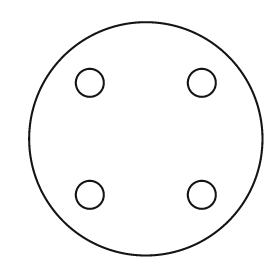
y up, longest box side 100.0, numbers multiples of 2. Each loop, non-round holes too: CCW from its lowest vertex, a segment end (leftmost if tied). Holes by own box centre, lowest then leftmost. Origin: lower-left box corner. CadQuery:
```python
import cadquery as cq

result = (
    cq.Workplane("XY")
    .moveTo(50.0, 50.0)
    .circle(50.0)
    .moveTo(26.0, 26.0)
    .circle(6.0)
    .moveTo(74.0, 26.0)
    .circle(6.0)
    .moveTo(26.0, 74.0)
    .circle(6.0)
    .moveTo(74.0, 74.0)
    .circle(6.0)
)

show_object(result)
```